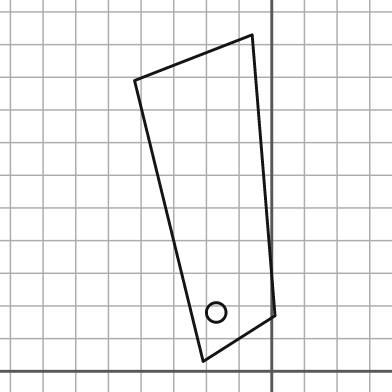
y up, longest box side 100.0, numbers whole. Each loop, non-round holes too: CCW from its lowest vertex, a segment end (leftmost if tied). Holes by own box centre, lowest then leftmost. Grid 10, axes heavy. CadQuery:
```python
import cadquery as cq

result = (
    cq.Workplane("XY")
    .moveTo(-21.0, 3.0)
    .lineTo(1.0, 17.0)
    .lineTo(-6.0, 103.0)
    .lineTo(-42.0, 89.0)
    .close()
    .moveTo(-17.0, 18.0)
    .circle(3.0)
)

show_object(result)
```